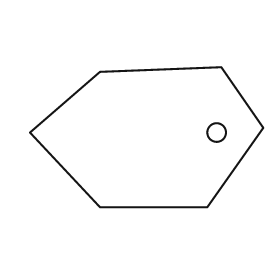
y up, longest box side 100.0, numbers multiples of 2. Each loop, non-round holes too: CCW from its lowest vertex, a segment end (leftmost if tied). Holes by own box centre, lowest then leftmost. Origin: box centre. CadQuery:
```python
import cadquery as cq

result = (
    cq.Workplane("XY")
    .moveTo(-20.0, -30.0)
    .lineTo(26.0, -30.0)
    .lineTo(50.0, 4.0)
    .lineTo(32.0, 30.0)
    .lineTo(-20.0, 28.0)
    .lineTo(-50.0, 2.0)
    .close()
    .moveTo(30.0, 2.0)
    .circle(4.0)
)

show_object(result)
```